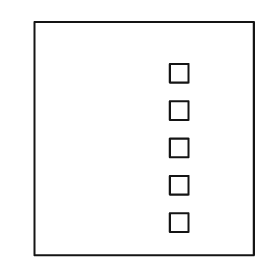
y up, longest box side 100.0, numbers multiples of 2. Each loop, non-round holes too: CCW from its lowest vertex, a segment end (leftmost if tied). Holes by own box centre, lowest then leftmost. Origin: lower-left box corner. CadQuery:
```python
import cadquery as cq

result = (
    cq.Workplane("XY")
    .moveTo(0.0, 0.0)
    .lineTo(94.0, 0.0)
    .lineTo(94.0, 100.0)
    .lineTo(0.0, 100.0)
    .close()
    .moveTo(58.0, 10.0)
    .lineTo(66.0, 10.0)
    .lineTo(66.0, 18.0)
    .lineTo(58.0, 18.0)
    .close()
    .moveTo(58.0, 26.0)
    .lineTo(66.0, 26.0)
    .lineTo(66.0, 34.0)
    .lineTo(58.0, 34.0)
    .close()
    .moveTo(58.0, 42.0)
    .lineTo(66.0, 42.0)
    .lineTo(66.0, 50.0)
    .lineTo(58.0, 50.0)
    .close()
    .moveTo(58.0, 58.0)
    .lineTo(66.0, 58.0)
    .lineTo(66.0, 66.0)
    .lineTo(58.0, 66.0)
    .close()
    .moveTo(58.0, 74.0)
    .lineTo(66.0, 74.0)
    .lineTo(66.0, 82.0)
    .lineTo(58.0, 82.0)
    .close()
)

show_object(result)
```